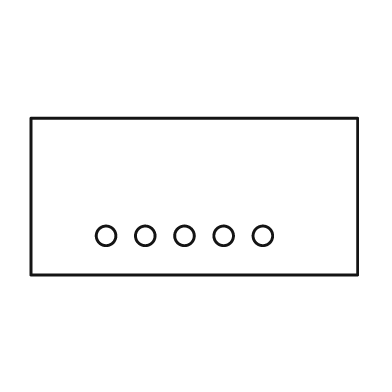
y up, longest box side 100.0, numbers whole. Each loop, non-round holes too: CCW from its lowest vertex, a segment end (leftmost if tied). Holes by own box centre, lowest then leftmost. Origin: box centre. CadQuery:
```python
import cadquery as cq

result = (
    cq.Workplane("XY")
    .moveTo(-50.0, -24.0)
    .lineTo(50.0, -24.0)
    .lineTo(50.0, 24.0)
    .lineTo(-50.0, 24.0)
    .close()
    .moveTo(-27.0, -12.0)
    .circle(3.0)
    .moveTo(-15.0, -12.0)
    .circle(3.0)
    .moveTo(-3.0, -12.0)
    .circle(3.0)
    .moveTo(9.0, -12.0)
    .circle(3.0)
    .moveTo(21.0, -12.0)
    .circle(3.0)
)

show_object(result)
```